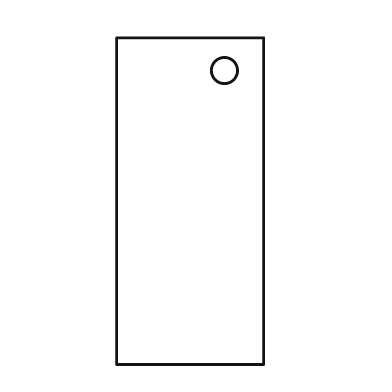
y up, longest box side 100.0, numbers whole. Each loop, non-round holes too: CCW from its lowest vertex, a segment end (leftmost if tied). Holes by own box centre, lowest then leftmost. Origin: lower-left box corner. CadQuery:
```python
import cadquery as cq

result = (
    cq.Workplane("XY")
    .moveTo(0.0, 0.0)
    .lineTo(45.0, 0.0)
    .lineTo(45.0, 100.0)
    .lineTo(0.0, 100.0)
    .close()
    .moveTo(33.0, 90.0)
    .circle(4.0)
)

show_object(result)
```